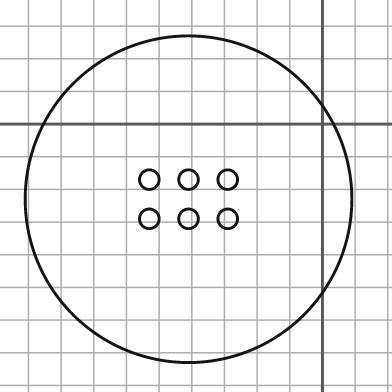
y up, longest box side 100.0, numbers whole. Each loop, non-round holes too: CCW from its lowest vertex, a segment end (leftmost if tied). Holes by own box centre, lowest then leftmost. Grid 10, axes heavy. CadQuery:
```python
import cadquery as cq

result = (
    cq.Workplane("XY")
    .moveTo(-41.0, -23.0)
    .circle(50.0)
    .moveTo(-53.0, -29.0)
    .circle(3.0)
    .moveTo(-41.0, -29.0)
    .circle(3.0)
    .moveTo(-29.0, -29.0)
    .circle(3.0)
    .moveTo(-53.0, -17.0)
    .circle(3.0)
    .moveTo(-41.0, -17.0)
    .circle(3.0)
    .moveTo(-29.0, -17.0)
    .circle(3.0)
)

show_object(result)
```